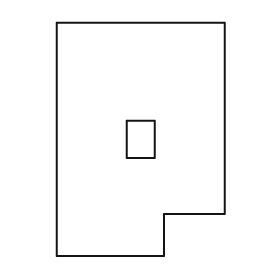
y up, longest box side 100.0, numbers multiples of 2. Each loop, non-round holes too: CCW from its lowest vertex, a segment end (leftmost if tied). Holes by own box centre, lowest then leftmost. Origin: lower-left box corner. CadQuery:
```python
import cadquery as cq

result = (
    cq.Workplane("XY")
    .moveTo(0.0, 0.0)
    .lineTo(46.0, 0.0)
    .lineTo(46.0, 18.0)
    .lineTo(72.0, 18.0)
    .lineTo(72.0, 100.0)
    .lineTo(0.0, 100.0)
    .close()
    .moveTo(30.0, 42.0)
    .lineTo(42.0, 42.0)
    .lineTo(42.0, 58.0)
    .lineTo(30.0, 58.0)
    .close()
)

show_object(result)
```